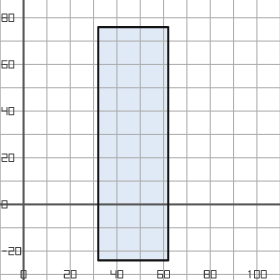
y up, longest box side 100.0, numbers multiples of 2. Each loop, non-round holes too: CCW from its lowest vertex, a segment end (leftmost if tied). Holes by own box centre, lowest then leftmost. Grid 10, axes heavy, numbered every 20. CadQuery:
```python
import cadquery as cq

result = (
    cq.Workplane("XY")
    .moveTo(32.0, -24.0)
    .lineTo(62.0, -24.0)
    .lineTo(62.0, 76.0)
    .lineTo(32.0, 76.0)
    .close()
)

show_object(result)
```